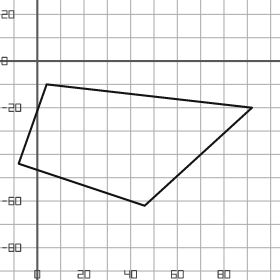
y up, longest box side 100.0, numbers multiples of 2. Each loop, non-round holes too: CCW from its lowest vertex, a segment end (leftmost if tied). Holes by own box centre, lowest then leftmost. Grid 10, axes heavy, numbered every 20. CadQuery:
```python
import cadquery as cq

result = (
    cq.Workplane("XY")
    .moveTo(46.0, -62.0)
    .lineTo(92.0, -20.0)
    .lineTo(4.0, -10.0)
    .lineTo(-8.0, -44.0)
    .close()
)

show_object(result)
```